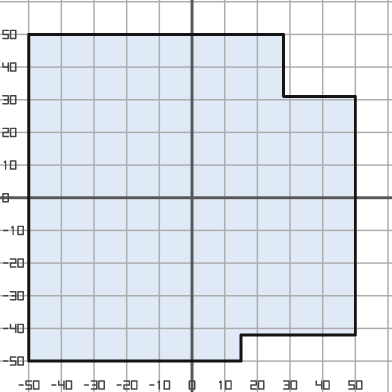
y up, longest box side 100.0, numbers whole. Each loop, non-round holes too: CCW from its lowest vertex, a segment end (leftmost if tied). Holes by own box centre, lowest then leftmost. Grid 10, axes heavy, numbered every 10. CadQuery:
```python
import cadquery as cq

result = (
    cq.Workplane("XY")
    .moveTo(-50.0, -50.0)
    .lineTo(15.0, -50.0)
    .lineTo(15.0, -42.0)
    .lineTo(50.0, -42.0)
    .lineTo(50.0, 31.0)
    .lineTo(28.0, 31.0)
    .lineTo(28.0, 50.0)
    .lineTo(-50.0, 50.0)
    .close()
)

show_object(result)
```